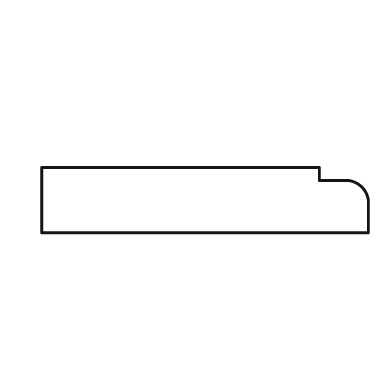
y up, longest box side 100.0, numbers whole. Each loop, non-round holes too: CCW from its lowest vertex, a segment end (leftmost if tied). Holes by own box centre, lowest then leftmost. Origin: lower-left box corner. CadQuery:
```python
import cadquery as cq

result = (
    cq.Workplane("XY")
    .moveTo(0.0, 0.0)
    .lineTo(100.0, 0.0)
    .lineTo(100.0, 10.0)
    .threePointArc((98.0, 14.0), (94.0, 16.0))
    .lineTo(85.0, 16.0)
    .lineTo(85.0, 20.0)
    .lineTo(0.0, 20.0)
    .close()
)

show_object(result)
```